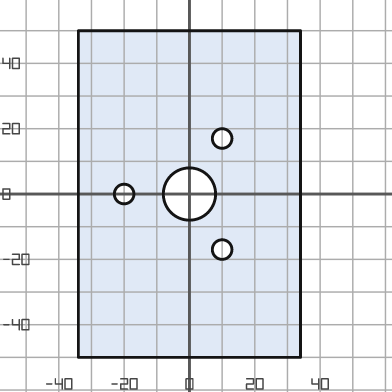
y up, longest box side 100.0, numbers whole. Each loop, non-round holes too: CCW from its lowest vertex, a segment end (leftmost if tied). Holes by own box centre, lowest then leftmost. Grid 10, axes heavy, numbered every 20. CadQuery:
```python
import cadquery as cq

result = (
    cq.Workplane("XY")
    .moveTo(-34.0, -50.0)
    .lineTo(34.0, -50.0)
    .lineTo(34.0, 50.0)
    .lineTo(-34.0, 50.0)
    .close()
    .moveTo(10.0, -17.0)
    .circle(3.0)
    .moveTo(-20.0, 0.0)
    .circle(3.0)
    .moveTo(0.0, 0.0)
    .circle(8.0)
    .moveTo(10.0, 17.0)
    .circle(3.0)
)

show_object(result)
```